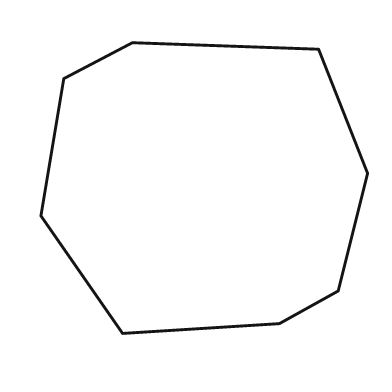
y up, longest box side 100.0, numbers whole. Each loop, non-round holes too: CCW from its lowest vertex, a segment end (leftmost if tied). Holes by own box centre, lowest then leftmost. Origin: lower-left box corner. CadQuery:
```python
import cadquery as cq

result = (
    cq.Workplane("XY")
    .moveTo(25.0, 0.0)
    .lineTo(73.0, 3.0)
    .lineTo(91.0, 13.0)
    .lineTo(100.0, 49.0)
    .lineTo(85.0, 87.0)
    .lineTo(28.0, 89.0)
    .lineTo(7.0, 78.0)
    .lineTo(0.0, 36.0)
    .close()
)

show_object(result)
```